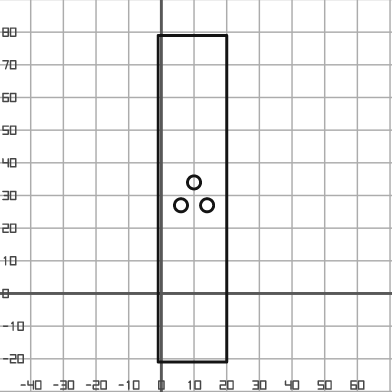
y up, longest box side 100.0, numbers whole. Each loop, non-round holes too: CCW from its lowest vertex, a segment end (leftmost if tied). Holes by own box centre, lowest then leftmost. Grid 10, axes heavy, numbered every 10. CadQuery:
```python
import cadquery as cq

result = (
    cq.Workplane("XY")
    .moveTo(-1.0, -21.0)
    .lineTo(20.0, -21.0)
    .lineTo(20.0, 79.0)
    .lineTo(-1.0, 79.0)
    .close()
    .moveTo(6.0, 27.0)
    .circle(2.0)
    .moveTo(14.0, 27.0)
    .circle(2.0)
    .moveTo(10.0, 34.0)
    .circle(2.0)
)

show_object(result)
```